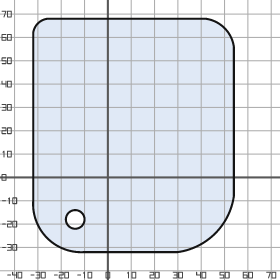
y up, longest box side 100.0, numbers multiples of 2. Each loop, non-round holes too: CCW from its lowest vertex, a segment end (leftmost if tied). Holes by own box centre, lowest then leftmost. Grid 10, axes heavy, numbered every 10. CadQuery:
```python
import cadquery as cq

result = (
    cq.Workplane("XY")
    .moveTo(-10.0, -32.0)
    .lineTo(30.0, -32.0)
    .threePointArc((46.0, -24.0), (54.0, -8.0))
    .lineTo(54.0, 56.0)
    .threePointArc((50.0, 64.0), (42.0, 68.0))
    .lineTo(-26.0, 68.0)
    .threePointArc((-30.0, 66.0), (-32.0, 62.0))
    .lineTo(-32.0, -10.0)
    .threePointArc((-26.0, -26.0), (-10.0, -32.0))
    .close()
    .moveTo(-14.0, -18.0)
    .circle(4.0)
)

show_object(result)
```